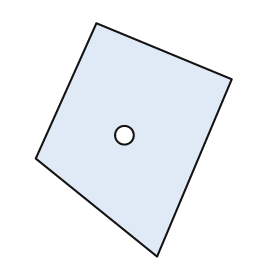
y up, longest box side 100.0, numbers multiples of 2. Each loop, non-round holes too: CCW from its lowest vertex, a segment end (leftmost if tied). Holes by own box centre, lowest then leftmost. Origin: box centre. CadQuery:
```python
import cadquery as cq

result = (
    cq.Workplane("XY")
    .moveTo(10.0, -50.0)
    .lineTo(42.0, 26.0)
    .lineTo(-16.0, 50.0)
    .lineTo(-42.0, -8.0)
    .close()
    .moveTo(-4.0, 2.0)
    .circle(4.0)
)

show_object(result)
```